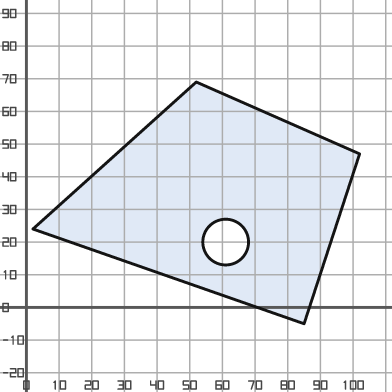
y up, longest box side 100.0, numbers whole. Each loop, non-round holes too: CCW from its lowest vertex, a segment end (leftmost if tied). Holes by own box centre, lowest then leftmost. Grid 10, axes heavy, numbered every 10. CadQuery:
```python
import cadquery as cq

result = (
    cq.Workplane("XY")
    .moveTo(85.0, -5.0)
    .lineTo(102.0, 47.0)
    .lineTo(52.0, 69.0)
    .lineTo(2.0, 24.0)
    .close()
    .moveTo(61.0, 20.0)
    .circle(7.0)
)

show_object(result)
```